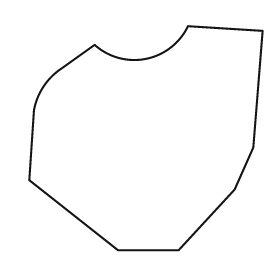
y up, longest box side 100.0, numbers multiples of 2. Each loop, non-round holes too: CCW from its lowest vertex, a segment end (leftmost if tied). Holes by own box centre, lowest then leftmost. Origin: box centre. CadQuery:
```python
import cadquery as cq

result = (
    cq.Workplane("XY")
    .moveTo(-12.0, -48.0)
    .lineTo(14.0, -48.0)
    .lineTo(38.0, -22.0)
    .lineTo(46.0, -4.0)
    .lineTo(50.0, 46.0)
    .lineTo(18.0, 48.0)
    .threePointArc((0.0, 34.0), (-22.0, 40.0))
    .lineTo(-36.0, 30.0)
    .threePointArc((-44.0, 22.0), (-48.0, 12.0))
    .lineTo(-50.0, -18.0)
    .close()
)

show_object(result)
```